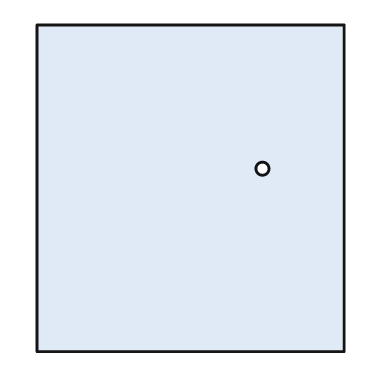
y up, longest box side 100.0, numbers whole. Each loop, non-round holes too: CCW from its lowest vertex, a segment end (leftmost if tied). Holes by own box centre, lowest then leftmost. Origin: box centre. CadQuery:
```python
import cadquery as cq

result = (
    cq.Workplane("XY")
    .moveTo(-47.0, -50.0)
    .lineTo(47.0, -50.0)
    .lineTo(47.0, 50.0)
    .lineTo(-47.0, 50.0)
    .close()
    .moveTo(22.0, 6.0)
    .circle(2.0)
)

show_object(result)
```